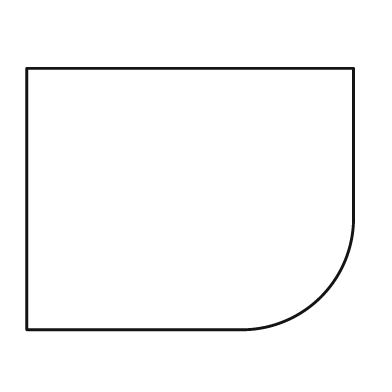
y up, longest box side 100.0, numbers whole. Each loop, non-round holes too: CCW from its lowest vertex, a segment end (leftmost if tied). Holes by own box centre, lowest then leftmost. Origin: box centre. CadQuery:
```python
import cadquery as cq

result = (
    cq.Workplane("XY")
    .moveTo(-50.0, -40.0)
    .lineTo(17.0, -40.0)
    .threePointArc((40.0, -30.0), (50.0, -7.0))
    .lineTo(50.0, 40.0)
    .lineTo(-50.0, 40.0)
    .close()
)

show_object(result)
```